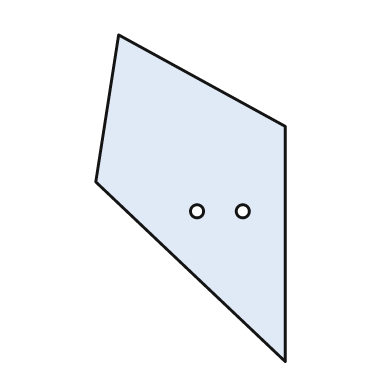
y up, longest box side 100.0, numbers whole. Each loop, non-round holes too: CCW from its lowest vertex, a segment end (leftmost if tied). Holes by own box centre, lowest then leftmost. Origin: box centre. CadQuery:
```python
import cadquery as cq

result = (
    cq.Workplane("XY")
    .moveTo(29.0, -50.0)
    .lineTo(29.0, 22.0)
    .lineTo(-22.0, 50.0)
    .lineTo(-29.0, 5.0)
    .close()
    .moveTo(2.0, -4.0)
    .circle(2.0)
    .moveTo(16.0, -4.0)
    .circle(2.0)
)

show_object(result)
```